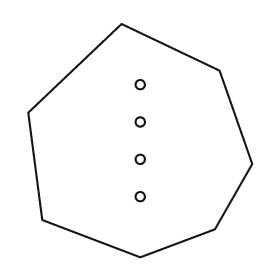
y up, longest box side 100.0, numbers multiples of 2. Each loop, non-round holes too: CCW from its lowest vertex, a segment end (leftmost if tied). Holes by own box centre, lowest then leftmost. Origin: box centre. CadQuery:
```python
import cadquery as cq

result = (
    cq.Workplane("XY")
    .moveTo(0.0, -50.0)
    .lineTo(32.0, -38.0)
    .lineTo(48.0, -10.0)
    .lineTo(34.0, 30.0)
    .lineTo(-8.0, 50.0)
    .lineTo(-48.0, 12.0)
    .lineTo(-42.0, -34.0)
    .close()
    .moveTo(0.0, -24.0)
    .circle(2.0)
    .moveTo(0.0, -8.0)
    .circle(2.0)
    .moveTo(0.0, 8.0)
    .circle(2.0)
    .moveTo(0.0, 24.0)
    .circle(2.0)
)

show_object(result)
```